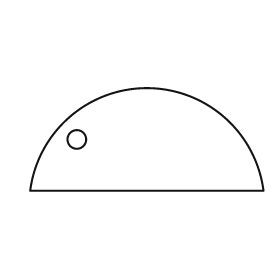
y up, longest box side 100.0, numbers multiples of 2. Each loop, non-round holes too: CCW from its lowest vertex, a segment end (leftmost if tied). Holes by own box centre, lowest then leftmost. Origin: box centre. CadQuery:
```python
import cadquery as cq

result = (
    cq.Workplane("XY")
    .moveTo(-50.0, -22.0)
    .lineTo(50.0, -22.0)
    .threePointArc((0.0, 22.0), (-50.0, -22.0))
    .close()
    .moveTo(-30.0, 0.0)
    .circle(4.0)
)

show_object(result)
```